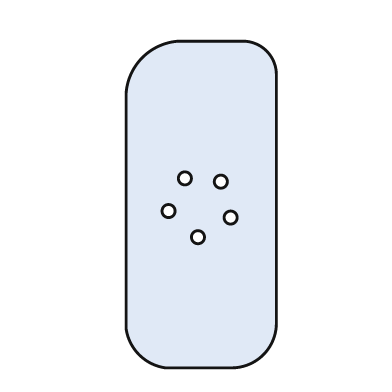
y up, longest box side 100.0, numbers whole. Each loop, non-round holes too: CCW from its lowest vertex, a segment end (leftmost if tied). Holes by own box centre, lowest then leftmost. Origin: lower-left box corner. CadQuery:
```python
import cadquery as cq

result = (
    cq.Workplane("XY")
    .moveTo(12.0, 0.0)
    .lineTo(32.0, 0.0)
    .threePointArc((42.0, 4.0), (46.0, 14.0))
    .lineTo(46.0, 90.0)
    .threePointArc((43.0, 97.0), (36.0, 100.0))
    .lineTo(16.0, 100.0)
    .threePointArc((5.0, 95.0), (0.0, 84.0))
    .lineTo(0.0, 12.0)
    .threePointArc((4.0, 4.0), (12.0, 0.0))
    .close()
    .moveTo(22.0, 40.0)
    .circle(2.0)
    .moveTo(32.0, 46.0)
    .circle(2.0)
    .moveTo(13.0, 48.0)
    .circle(2.0)
    .moveTo(29.0, 57.0)
    .circle(2.0)
    .moveTo(18.0, 58.0)
    .circle(2.0)
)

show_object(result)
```